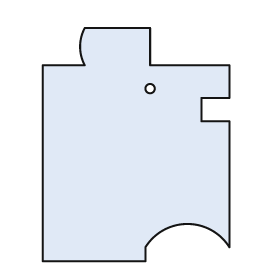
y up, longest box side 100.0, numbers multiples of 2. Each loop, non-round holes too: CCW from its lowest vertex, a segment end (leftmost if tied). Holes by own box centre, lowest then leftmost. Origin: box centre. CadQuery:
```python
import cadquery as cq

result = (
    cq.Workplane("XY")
    .moveTo(-40.0, -50.0)
    .lineTo(4.0, -50.0)
    .lineTo(4.0, -44.0)
    .threePointArc((22.0, -34.0), (40.0, -44.0))
    .lineTo(40.0, 10.0)
    .lineTo(28.0, 10.0)
    .lineTo(28.0, 20.0)
    .lineTo(40.0, 20.0)
    .lineTo(40.0, 34.0)
    .lineTo(6.0, 34.0)
    .lineTo(6.0, 50.0)
    .lineTo(-22.0, 50.0)
    .threePointArc((-24.0, 42.0), (-22.0, 34.0))
    .lineTo(-40.0, 34.0)
    .close()
    .moveTo(6.0, 24.0)
    .circle(2.0)
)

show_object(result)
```